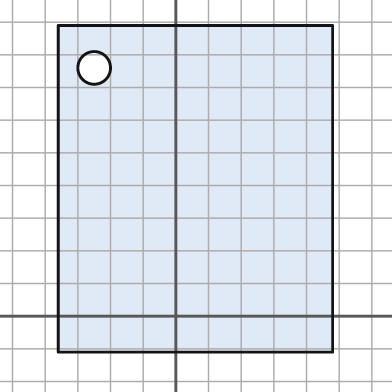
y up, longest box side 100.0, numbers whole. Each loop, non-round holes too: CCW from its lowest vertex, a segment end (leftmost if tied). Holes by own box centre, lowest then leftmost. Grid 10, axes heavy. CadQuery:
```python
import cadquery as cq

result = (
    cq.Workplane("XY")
    .moveTo(-36.0, -11.0)
    .lineTo(48.0, -11.0)
    .lineTo(48.0, 89.0)
    .lineTo(-36.0, 89.0)
    .close()
    .moveTo(-25.0, 76.0)
    .circle(5.0)
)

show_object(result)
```